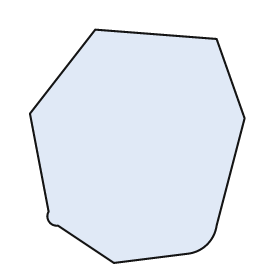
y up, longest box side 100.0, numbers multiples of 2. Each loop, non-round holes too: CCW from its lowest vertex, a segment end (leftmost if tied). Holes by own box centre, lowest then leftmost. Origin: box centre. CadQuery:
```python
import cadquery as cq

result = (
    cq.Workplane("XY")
    .moveTo(-10.0, -50.0)
    .lineTo(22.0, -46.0)
    .threePointArc((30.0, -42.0), (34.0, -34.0))
    .lineTo(46.0, 12.0)
    .lineTo(34.0, 46.0)
    .lineTo(-18.0, 50.0)
    .lineTo(-46.0, 14.0)
    .lineTo(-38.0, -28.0)
    .threePointArc((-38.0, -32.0), (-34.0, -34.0))
    .close()
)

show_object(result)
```